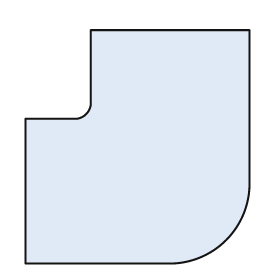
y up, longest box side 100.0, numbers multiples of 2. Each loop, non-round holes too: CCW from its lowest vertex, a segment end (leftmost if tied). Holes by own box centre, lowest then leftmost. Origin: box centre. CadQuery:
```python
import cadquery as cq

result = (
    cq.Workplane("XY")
    .moveTo(-48.0, -50.0)
    .lineTo(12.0, -50.0)
    .threePointArc((38.0, -40.0), (48.0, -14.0))
    .lineTo(48.0, 50.0)
    .lineTo(-20.0, 50.0)
    .lineTo(-20.0, 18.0)
    .threePointArc((-22.0, 14.0), (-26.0, 12.0))
    .lineTo(-48.0, 12.0)
    .close()
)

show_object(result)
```